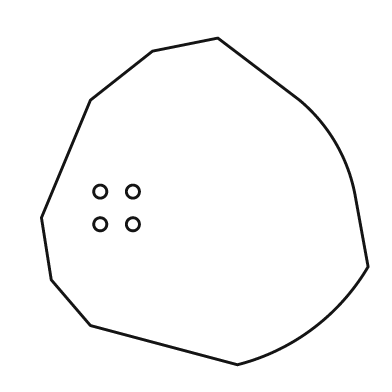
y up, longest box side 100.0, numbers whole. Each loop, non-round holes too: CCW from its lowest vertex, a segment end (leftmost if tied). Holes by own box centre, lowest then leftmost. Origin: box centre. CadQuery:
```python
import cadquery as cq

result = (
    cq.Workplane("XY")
    .moveTo(10.0, -50.0)
    .threePointArc((33.0, -39.0), (50.0, -20.0))
    .lineTo(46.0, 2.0)
    .threePointArc((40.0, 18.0), (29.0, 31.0))
    .lineTo(4.0, 50.0)
    .lineTo(-16.0, 46.0)
    .lineTo(-35.0, 31.0)
    .lineTo(-50.0, -5.0)
    .lineTo(-47.0, -24.0)
    .lineTo(-35.0, -38.0)
    .close()
    .moveTo(-32.0, -7.0)
    .circle(2.0)
    .moveTo(-22.0, -7.0)
    .circle(2.0)
    .moveTo(-32.0, 3.0)
    .circle(2.0)
    .moveTo(-22.0, 3.0)
    .circle(2.0)
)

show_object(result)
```